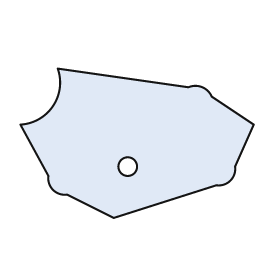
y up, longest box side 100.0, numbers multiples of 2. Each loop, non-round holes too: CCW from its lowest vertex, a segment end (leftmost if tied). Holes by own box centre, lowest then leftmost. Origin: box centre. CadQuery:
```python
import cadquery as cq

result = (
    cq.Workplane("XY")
    .moveTo(-10.0, -32.0)
    .lineTo(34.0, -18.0)
    .threePointArc((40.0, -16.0), (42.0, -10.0))
    .lineTo(50.0, 8.0)
    .lineTo(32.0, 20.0)
    .threePointArc((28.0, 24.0), (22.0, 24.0))
    .lineTo(-34.0, 32.0)
    .threePointArc((-36.0, 16.0), (-50.0, 8.0))
    .lineTo(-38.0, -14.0)
    .threePointArc((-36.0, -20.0), (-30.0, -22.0))
    .close()
    .moveTo(-4.0, -10.0)
    .circle(4.0)
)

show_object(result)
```